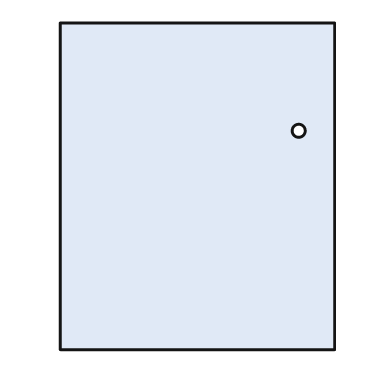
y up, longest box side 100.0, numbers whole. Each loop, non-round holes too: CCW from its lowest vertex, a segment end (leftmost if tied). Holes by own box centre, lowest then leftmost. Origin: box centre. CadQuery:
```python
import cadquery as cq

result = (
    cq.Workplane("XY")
    .moveTo(-42.0, -50.0)
    .lineTo(42.0, -50.0)
    .lineTo(42.0, 50.0)
    .lineTo(-42.0, 50.0)
    .close()
    .moveTo(31.0, 17.0)
    .circle(2.0)
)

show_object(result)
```